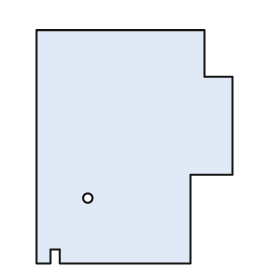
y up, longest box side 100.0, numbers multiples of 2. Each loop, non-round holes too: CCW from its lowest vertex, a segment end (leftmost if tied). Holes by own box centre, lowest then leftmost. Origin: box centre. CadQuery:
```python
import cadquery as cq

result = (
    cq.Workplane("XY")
    .moveTo(-42.0, -50.0)
    .lineTo(-36.0, -50.0)
    .lineTo(-36.0, -44.0)
    .lineTo(-32.0, -44.0)
    .lineTo(-32.0, -50.0)
    .lineTo(24.0, -50.0)
    .lineTo(24.0, -12.0)
    .lineTo(42.0, -12.0)
    .lineTo(42.0, 30.0)
    .lineTo(30.0, 30.0)
    .lineTo(30.0, 50.0)
    .lineTo(-42.0, 50.0)
    .close()
    .moveTo(-20.0, -22.0)
    .circle(2.0)
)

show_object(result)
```